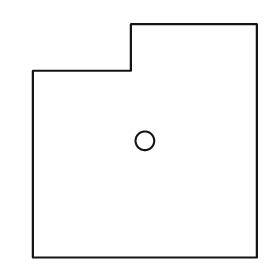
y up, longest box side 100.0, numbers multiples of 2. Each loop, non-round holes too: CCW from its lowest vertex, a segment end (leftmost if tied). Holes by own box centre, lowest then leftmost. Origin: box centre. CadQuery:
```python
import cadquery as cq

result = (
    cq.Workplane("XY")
    .moveTo(-48.0, -50.0)
    .lineTo(48.0, -50.0)
    .lineTo(48.0, 50.0)
    .lineTo(-6.0, 50.0)
    .lineTo(-6.0, 30.0)
    .lineTo(-48.0, 30.0)
    .close()
    .moveTo(0.0, 0.0)
    .circle(4.0)
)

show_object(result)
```